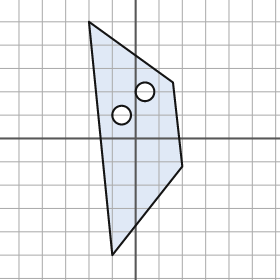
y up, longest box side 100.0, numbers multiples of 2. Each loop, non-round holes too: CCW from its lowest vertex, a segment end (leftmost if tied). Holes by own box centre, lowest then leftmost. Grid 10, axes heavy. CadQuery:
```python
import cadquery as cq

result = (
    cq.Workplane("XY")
    .moveTo(-10.0, -50.0)
    .lineTo(20.0, -12.0)
    .lineTo(16.0, 24.0)
    .lineTo(-20.0, 50.0)
    .close()
    .moveTo(-6.0, 10.0)
    .circle(4.0)
    .moveTo(4.0, 20.0)
    .circle(4.0)
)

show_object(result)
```